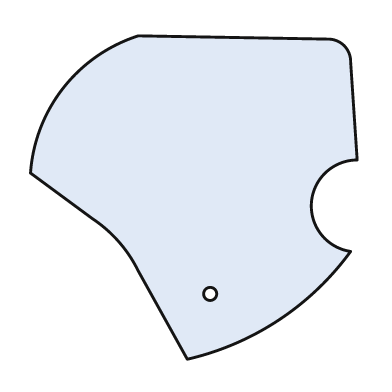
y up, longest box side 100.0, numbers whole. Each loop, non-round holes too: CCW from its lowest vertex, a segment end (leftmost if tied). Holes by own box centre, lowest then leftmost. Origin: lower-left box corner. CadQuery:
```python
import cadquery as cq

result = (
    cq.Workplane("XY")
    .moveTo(48.0, 0.0)
    .threePointArc((76.0, 12.0), (98.0, 33.0))
    .threePointArc((86.0, 48.0), (100.0, 61.0))
    .lineTo(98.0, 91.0)
    .threePointArc((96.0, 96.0), (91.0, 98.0))
    .lineTo(33.0, 99.0)
    .threePointArc((10.0, 83.0), (0.0, 57.0))
    .lineTo(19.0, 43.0)
    .threePointArc((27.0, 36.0), (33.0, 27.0))
    .close()
    .moveTo(55.0, 20.0)
    .circle(2.0)
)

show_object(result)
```